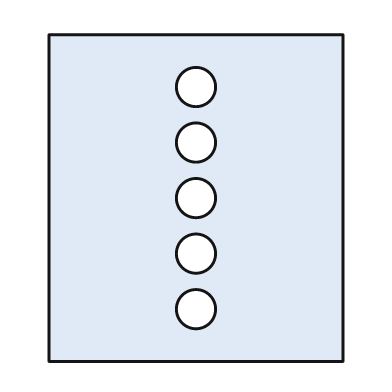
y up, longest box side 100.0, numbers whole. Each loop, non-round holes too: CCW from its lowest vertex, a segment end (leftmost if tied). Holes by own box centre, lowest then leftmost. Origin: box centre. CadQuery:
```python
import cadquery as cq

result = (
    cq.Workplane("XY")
    .moveTo(-45.0, -50.0)
    .lineTo(45.0, -50.0)
    .lineTo(45.0, 50.0)
    .lineTo(-45.0, 50.0)
    .close()
    .moveTo(0.0, -34.0)
    .circle(6.0)
    .moveTo(0.0, -17.0)
    .circle(6.0)
    .moveTo(0.0, 0.0)
    .circle(6.0)
    .moveTo(0.0, 17.0)
    .circle(6.0)
    .moveTo(0.0, 34.0)
    .circle(6.0)
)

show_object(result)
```